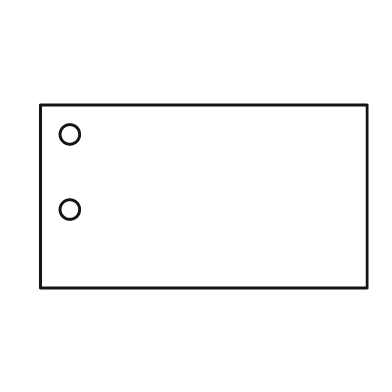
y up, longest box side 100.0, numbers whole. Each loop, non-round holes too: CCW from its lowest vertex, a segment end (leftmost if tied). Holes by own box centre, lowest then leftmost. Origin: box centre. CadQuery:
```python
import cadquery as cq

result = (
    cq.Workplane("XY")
    .moveTo(-50.0, -28.0)
    .lineTo(50.0, -28.0)
    .lineTo(50.0, 28.0)
    .lineTo(-50.0, 28.0)
    .close()
    .moveTo(-41.0, -4.0)
    .circle(3.0)
    .moveTo(-41.0, 19.0)
    .circle(3.0)
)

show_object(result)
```